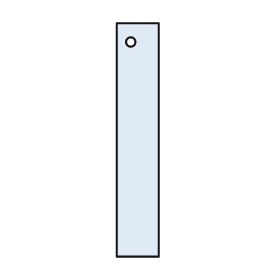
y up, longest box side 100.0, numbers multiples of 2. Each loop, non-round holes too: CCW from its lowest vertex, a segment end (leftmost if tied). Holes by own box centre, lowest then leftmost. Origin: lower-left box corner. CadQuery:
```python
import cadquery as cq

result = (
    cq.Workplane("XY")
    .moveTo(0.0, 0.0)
    .lineTo(18.0, 0.0)
    .lineTo(18.0, 100.0)
    .lineTo(0.0, 100.0)
    .close()
    .moveTo(6.0, 92.0)
    .circle(2.0)
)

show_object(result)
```